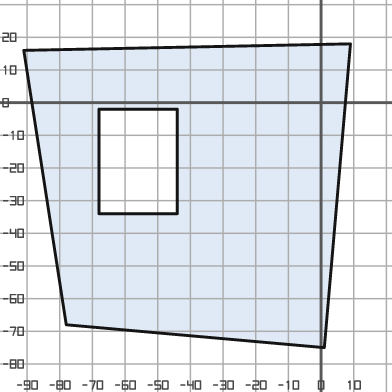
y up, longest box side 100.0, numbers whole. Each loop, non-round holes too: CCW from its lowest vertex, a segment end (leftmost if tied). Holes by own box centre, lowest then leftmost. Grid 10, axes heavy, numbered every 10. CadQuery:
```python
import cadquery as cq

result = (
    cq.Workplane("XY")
    .moveTo(1.0, -75.0)
    .lineTo(9.0, 18.0)
    .lineTo(-91.0, 16.0)
    .lineTo(-78.0, -68.0)
    .close()
    .moveTo(-68.0, -34.0)
    .lineTo(-44.0, -34.0)
    .lineTo(-44.0, -2.0)
    .lineTo(-68.0, -2.0)
    .close()
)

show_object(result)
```